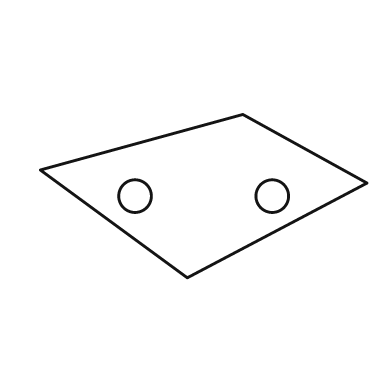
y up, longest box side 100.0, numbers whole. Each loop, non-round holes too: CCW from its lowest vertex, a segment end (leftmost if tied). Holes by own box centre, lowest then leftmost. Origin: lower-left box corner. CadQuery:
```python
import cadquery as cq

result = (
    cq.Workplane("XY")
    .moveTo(45.0, 0.0)
    .lineTo(100.0, 29.0)
    .lineTo(62.0, 50.0)
    .lineTo(0.0, 33.0)
    .close()
    .moveTo(29.0, 25.0)
    .circle(5.0)
    .moveTo(71.0, 25.0)
    .circle(5.0)
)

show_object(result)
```